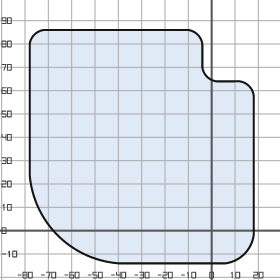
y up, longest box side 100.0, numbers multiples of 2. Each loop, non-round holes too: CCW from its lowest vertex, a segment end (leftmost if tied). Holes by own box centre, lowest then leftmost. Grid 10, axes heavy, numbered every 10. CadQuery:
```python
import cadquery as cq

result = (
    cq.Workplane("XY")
    .moveTo(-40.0, -14.0)
    .lineTo(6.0, -14.0)
    .threePointArc((14.0, -10.0), (18.0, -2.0))
    .lineTo(18.0, 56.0)
    .threePointArc((16.0, 62.0), (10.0, 64.0))
    .lineTo(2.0, 64.0)
    .threePointArc((-2.0, 66.0), (-4.0, 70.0))
    .lineTo(-4.0, 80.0)
    .threePointArc((-6.0, 84.0), (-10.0, 86.0))
    .lineTo(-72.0, 86.0)
    .threePointArc((-76.0, 84.0), (-78.0, 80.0))
    .lineTo(-78.0, 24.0)
    .threePointArc((-66.0, -2.0), (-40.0, -14.0))
    .close()
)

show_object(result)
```